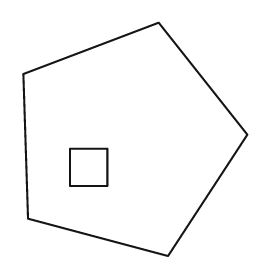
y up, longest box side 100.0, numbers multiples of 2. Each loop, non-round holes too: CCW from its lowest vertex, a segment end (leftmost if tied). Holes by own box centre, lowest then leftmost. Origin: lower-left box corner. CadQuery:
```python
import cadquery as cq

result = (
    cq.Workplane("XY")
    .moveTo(62.0, 0.0)
    .lineTo(96.0, 52.0)
    .lineTo(58.0, 100.0)
    .lineTo(0.0, 78.0)
    .lineTo(2.0, 16.0)
    .close()
    .moveTo(20.0, 30.0)
    .lineTo(36.0, 30.0)
    .lineTo(36.0, 46.0)
    .lineTo(20.0, 46.0)
    .close()
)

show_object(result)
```